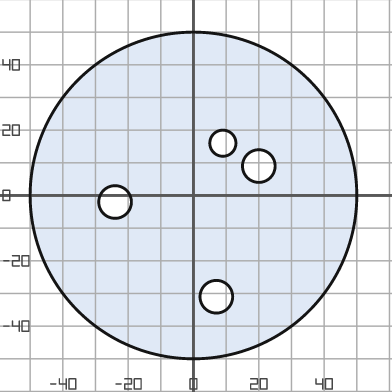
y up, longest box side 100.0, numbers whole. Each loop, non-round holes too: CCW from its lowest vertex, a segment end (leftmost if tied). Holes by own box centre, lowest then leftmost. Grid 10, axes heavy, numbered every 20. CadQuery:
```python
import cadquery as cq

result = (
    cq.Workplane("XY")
    .moveTo(0.0, 0.0)
    .circle(50.0)
    .moveTo(7.0, -31.0)
    .circle(5.0)
    .moveTo(-24.0, -2.0)
    .circle(5.0)
    .moveTo(20.0, 9.0)
    .circle(5.0)
    .moveTo(9.0, 16.0)
    .circle(4.0)
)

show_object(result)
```